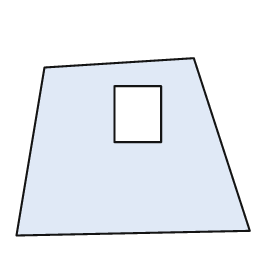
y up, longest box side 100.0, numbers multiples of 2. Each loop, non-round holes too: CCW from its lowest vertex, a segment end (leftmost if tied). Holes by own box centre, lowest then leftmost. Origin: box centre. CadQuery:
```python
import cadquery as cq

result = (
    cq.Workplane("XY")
    .moveTo(-50.0, -38.0)
    .lineTo(50.0, -36.0)
    .lineTo(26.0, 38.0)
    .lineTo(-38.0, 34.0)
    .close()
    .moveTo(-8.0, 2.0)
    .lineTo(12.0, 2.0)
    .lineTo(12.0, 26.0)
    .lineTo(-8.0, 26.0)
    .close()
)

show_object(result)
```